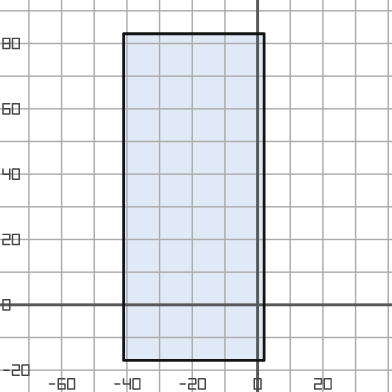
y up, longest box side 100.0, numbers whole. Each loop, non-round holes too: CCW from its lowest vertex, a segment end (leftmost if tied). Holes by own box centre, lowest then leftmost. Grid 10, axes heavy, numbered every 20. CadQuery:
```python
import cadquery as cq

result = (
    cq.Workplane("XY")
    .moveTo(-41.0, -17.0)
    .lineTo(2.0, -17.0)
    .lineTo(2.0, 83.0)
    .lineTo(-41.0, 83.0)
    .close()
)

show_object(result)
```